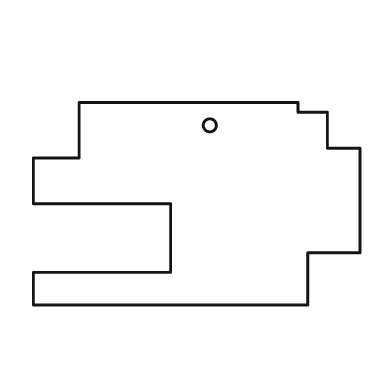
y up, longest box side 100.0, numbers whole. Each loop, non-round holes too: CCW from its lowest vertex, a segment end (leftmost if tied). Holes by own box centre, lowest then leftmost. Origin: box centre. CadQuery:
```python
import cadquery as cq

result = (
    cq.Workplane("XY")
    .moveTo(-50.0, -31.0)
    .lineTo(34.0, -31.0)
    .lineTo(34.0, -15.0)
    .lineTo(50.0, -15.0)
    .lineTo(50.0, 17.0)
    .lineTo(40.0, 17.0)
    .lineTo(40.0, 28.0)
    .lineTo(31.0, 28.0)
    .lineTo(31.0, 31.0)
    .lineTo(-36.0, 31.0)
    .lineTo(-36.0, 14.0)
    .lineTo(-50.0, 14.0)
    .lineTo(-50.0, 0.0)
    .lineTo(-8.0, 0.0)
    .lineTo(-8.0, -21.0)
    .lineTo(-50.0, -21.0)
    .close()
    .moveTo(4.0, 24.0)
    .circle(2.0)
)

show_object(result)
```